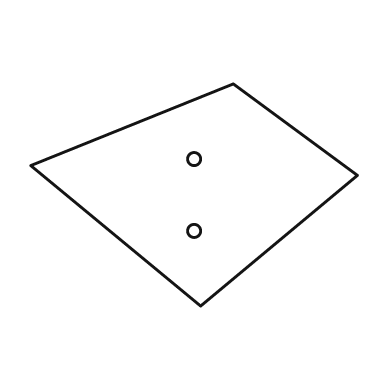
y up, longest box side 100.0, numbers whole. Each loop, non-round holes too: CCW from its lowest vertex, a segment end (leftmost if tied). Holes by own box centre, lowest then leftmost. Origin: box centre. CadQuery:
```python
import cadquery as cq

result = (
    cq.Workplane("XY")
    .moveTo(2.0, -34.0)
    .lineTo(50.0, 6.0)
    .lineTo(12.0, 34.0)
    .lineTo(-50.0, 9.0)
    .close()
    .moveTo(0.0, -11.0)
    .circle(2.0)
    .moveTo(0.0, 11.0)
    .circle(2.0)
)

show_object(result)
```